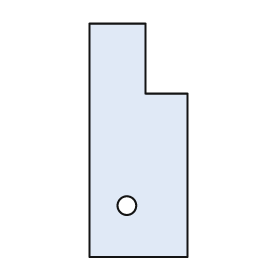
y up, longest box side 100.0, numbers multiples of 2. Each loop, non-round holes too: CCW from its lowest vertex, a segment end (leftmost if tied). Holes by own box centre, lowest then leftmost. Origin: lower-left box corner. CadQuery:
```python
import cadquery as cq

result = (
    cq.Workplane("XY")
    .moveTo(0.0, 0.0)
    .lineTo(42.0, 0.0)
    .lineTo(42.0, 70.0)
    .lineTo(24.0, 70.0)
    .lineTo(24.0, 100.0)
    .lineTo(0.0, 100.0)
    .close()
    .moveTo(16.0, 22.0)
    .circle(4.0)
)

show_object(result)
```